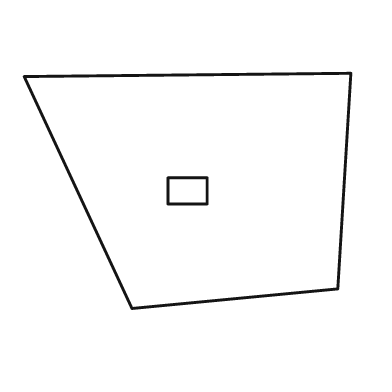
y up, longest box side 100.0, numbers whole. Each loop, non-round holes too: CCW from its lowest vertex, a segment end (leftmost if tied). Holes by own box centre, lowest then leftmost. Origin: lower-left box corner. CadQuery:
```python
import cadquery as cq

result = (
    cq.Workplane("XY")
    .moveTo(33.0, 0.0)
    .lineTo(96.0, 6.0)
    .lineTo(100.0, 72.0)
    .lineTo(0.0, 71.0)
    .close()
    .moveTo(44.0, 32.0)
    .lineTo(56.0, 32.0)
    .lineTo(56.0, 40.0)
    .lineTo(44.0, 40.0)
    .close()
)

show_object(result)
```